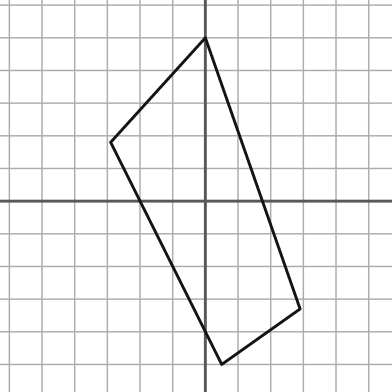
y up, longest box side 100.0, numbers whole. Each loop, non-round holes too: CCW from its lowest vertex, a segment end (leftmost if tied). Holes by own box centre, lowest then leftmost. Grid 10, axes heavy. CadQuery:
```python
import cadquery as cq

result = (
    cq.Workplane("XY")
    .moveTo(5.0, -50.0)
    .lineTo(29.0, -33.0)
    .lineTo(0.0, 50.0)
    .lineTo(-29.0, 18.0)
    .close()
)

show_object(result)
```